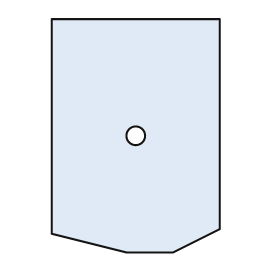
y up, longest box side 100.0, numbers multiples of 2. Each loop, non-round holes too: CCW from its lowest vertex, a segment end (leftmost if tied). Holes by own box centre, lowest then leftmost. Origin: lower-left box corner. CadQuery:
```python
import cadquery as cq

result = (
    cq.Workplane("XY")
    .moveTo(32.0, 0.0)
    .lineTo(52.0, 0.0)
    .lineTo(72.0, 10.0)
    .lineTo(72.0, 100.0)
    .lineTo(0.0, 100.0)
    .lineTo(0.0, 8.0)
    .close()
    .moveTo(36.0, 50.0)
    .circle(4.0)
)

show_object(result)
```